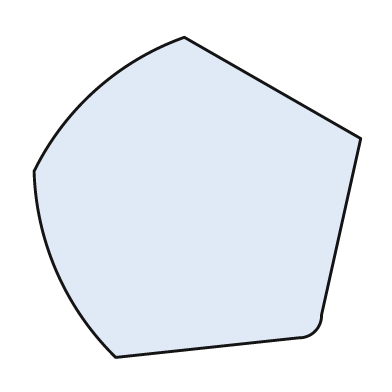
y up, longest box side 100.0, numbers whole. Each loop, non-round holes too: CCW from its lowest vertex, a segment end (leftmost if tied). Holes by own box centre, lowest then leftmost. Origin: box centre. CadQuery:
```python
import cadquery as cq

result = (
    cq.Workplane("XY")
    .moveTo(-25.0, -49.0)
    .lineTo(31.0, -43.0)
    .threePointArc((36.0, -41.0), (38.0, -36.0))
    .lineTo(50.0, 18.0)
    .lineTo(-4.0, 49.0)
    .threePointArc((-31.0, 33.0), (-50.0, 8.0))
    .threePointArc((-43.0, -23.0), (-25.0, -49.0))
    .close()
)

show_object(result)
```